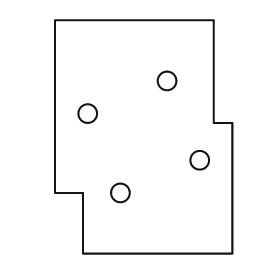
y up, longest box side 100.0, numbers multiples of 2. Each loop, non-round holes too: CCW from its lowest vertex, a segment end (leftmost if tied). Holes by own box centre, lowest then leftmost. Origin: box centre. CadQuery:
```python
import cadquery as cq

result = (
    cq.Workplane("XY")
    .moveTo(-26.0, -50.0)
    .lineTo(38.0, -50.0)
    .lineTo(38.0, 6.0)
    .lineTo(30.0, 6.0)
    .lineTo(30.0, 50.0)
    .lineTo(-38.0, 50.0)
    .lineTo(-38.0, -24.0)
    .lineTo(-26.0, -24.0)
    .close()
    .moveTo(-10.0, -24.0)
    .circle(4.0)
    .moveTo(24.0, -10.0)
    .circle(4.0)
    .moveTo(-24.0, 10.0)
    .circle(4.0)
    .moveTo(10.0, 24.0)
    .circle(4.0)
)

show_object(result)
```